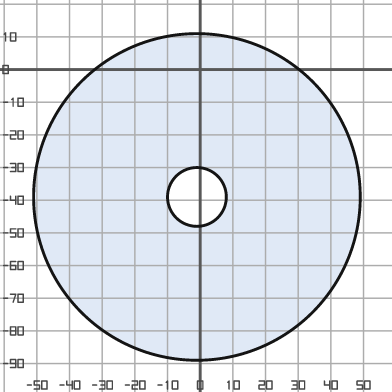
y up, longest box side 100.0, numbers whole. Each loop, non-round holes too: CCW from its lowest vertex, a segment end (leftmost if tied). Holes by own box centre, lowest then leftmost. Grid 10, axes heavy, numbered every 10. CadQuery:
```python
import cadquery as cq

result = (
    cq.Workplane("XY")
    .moveTo(-1.0, -39.0)
    .circle(50.0)
    .moveTo(-1.0, -39.0)
    .circle(9.0)
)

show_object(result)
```